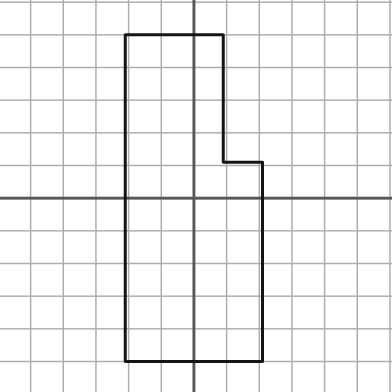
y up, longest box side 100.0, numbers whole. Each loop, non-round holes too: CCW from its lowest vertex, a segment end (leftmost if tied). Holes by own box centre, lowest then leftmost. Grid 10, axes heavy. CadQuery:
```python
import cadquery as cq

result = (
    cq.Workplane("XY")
    .moveTo(-21.0, -50.0)
    .lineTo(21.0, -50.0)
    .lineTo(21.0, 11.0)
    .lineTo(9.0, 11.0)
    .lineTo(9.0, 50.0)
    .lineTo(-21.0, 50.0)
    .close()
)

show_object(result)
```